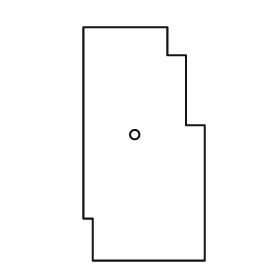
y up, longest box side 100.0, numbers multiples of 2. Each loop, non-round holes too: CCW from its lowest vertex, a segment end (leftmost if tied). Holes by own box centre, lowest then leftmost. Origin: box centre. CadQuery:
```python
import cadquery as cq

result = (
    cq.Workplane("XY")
    .moveTo(-22.0, -50.0)
    .lineTo(26.0, -50.0)
    .lineTo(26.0, 8.0)
    .lineTo(18.0, 8.0)
    .lineTo(18.0, 38.0)
    .lineTo(10.0, 38.0)
    .lineTo(10.0, 50.0)
    .lineTo(-26.0, 50.0)
    .lineTo(-26.0, -32.0)
    .lineTo(-22.0, -32.0)
    .close()
    .moveTo(-4.0, 4.0)
    .circle(2.0)
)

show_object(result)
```